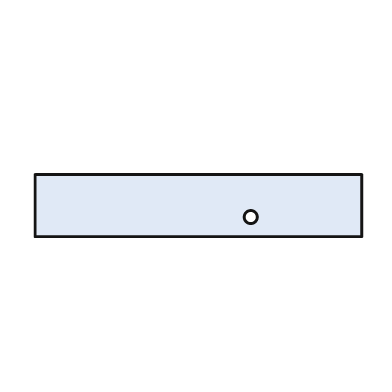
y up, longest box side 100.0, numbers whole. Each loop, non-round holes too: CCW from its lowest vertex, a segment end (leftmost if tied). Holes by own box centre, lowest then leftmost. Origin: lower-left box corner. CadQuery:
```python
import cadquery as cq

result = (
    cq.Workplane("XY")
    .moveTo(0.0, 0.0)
    .lineTo(100.0, 0.0)
    .lineTo(100.0, 19.0)
    .lineTo(0.0, 19.0)
    .close()
    .moveTo(66.0, 6.0)
    .circle(2.0)
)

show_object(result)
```